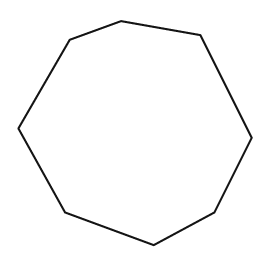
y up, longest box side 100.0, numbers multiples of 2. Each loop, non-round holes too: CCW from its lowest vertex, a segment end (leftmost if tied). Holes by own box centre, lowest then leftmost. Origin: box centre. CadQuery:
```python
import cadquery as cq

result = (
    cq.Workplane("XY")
    .moveTo(8.0, -48.0)
    .lineTo(34.0, -34.0)
    .lineTo(50.0, -2.0)
    .lineTo(28.0, 42.0)
    .lineTo(-6.0, 48.0)
    .lineTo(-28.0, 40.0)
    .lineTo(-50.0, 2.0)
    .lineTo(-30.0, -34.0)
    .close()
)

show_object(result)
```